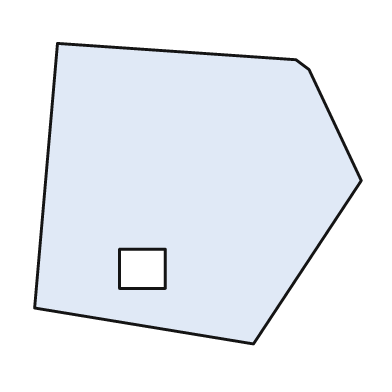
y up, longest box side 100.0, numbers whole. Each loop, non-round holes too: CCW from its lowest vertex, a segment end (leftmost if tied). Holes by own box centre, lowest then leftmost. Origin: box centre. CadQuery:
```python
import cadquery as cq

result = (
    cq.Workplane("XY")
    .moveTo(17.0, -46.0)
    .lineTo(50.0, 4.0)
    .lineTo(34.0, 38.0)
    .lineTo(30.0, 41.0)
    .lineTo(-43.0, 46.0)
    .lineTo(-50.0, -35.0)
    .close()
    .moveTo(-24.0, -29.0)
    .lineTo(-10.0, -29.0)
    .lineTo(-10.0, -17.0)
    .lineTo(-24.0, -17.0)
    .close()
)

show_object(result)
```